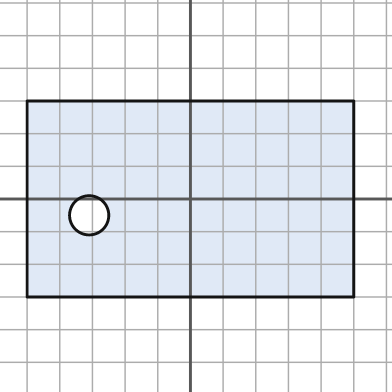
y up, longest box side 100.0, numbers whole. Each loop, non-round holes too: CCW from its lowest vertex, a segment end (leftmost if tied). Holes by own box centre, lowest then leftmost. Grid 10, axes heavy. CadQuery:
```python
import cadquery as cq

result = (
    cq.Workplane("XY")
    .moveTo(-50.0, -30.0)
    .lineTo(50.0, -30.0)
    .lineTo(50.0, 30.0)
    .lineTo(-50.0, 30.0)
    .close()
    .moveTo(-31.0, -5.0)
    .circle(6.0)
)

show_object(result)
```